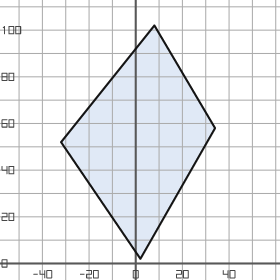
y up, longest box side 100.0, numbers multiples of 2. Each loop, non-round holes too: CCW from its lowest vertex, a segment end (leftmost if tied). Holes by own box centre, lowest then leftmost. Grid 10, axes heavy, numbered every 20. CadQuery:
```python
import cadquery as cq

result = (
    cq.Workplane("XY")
    .moveTo(2.0, 2.0)
    .lineTo(34.0, 58.0)
    .lineTo(8.0, 102.0)
    .lineTo(-32.0, 52.0)
    .close()
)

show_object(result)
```